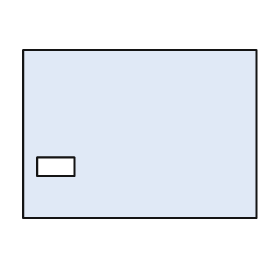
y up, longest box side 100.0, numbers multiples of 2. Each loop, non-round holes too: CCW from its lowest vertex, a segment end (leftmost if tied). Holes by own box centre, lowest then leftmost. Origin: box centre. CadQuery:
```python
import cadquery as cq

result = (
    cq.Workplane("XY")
    .moveTo(-50.0, -36.0)
    .lineTo(50.0, -36.0)
    .lineTo(50.0, 36.0)
    .lineTo(-50.0, 36.0)
    .close()
    .moveTo(-44.0, -18.0)
    .lineTo(-28.0, -18.0)
    .lineTo(-28.0, -10.0)
    .lineTo(-44.0, -10.0)
    .close()
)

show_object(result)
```